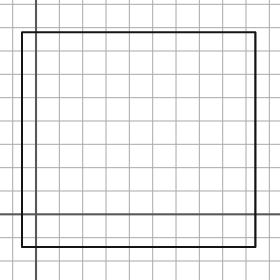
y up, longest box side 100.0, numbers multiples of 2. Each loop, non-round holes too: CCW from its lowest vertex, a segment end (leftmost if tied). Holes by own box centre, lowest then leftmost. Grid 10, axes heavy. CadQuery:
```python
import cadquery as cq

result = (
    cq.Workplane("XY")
    .moveTo(-6.0, -14.0)
    .lineTo(94.0, -14.0)
    .lineTo(94.0, 78.0)
    .lineTo(-6.0, 78.0)
    .close()
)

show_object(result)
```